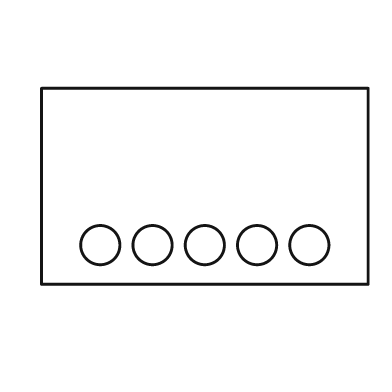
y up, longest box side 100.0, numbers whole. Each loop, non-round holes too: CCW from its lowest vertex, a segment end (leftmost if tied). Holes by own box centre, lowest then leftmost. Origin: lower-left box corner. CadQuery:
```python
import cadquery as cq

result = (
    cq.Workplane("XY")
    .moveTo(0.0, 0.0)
    .lineTo(100.0, 0.0)
    .lineTo(100.0, 60.0)
    .lineTo(0.0, 60.0)
    .close()
    .moveTo(18.0, 12.0)
    .circle(6.0)
    .moveTo(34.0, 12.0)
    .circle(6.0)
    .moveTo(50.0, 12.0)
    .circle(6.0)
    .moveTo(66.0, 12.0)
    .circle(6.0)
    .moveTo(82.0, 12.0)
    .circle(6.0)
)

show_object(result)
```